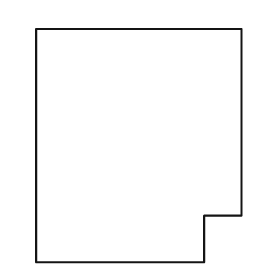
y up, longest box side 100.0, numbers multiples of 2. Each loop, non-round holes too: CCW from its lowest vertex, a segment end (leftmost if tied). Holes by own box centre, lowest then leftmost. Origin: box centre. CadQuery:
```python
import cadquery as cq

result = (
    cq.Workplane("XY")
    .moveTo(-44.0, -50.0)
    .lineTo(28.0, -50.0)
    .lineTo(28.0, -30.0)
    .lineTo(44.0, -30.0)
    .lineTo(44.0, 50.0)
    .lineTo(-44.0, 50.0)
    .close()
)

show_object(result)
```